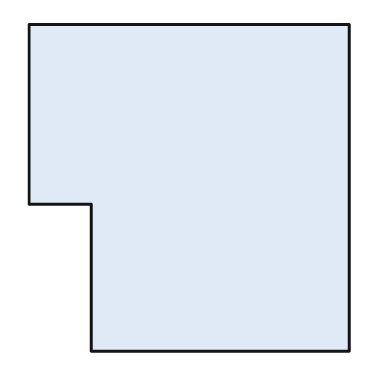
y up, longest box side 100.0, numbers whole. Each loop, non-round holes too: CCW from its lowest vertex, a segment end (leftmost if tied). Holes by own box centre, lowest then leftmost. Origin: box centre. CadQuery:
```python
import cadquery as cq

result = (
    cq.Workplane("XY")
    .moveTo(-30.0, -50.0)
    .lineTo(49.0, -50.0)
    .lineTo(49.0, 50.0)
    .lineTo(-49.0, 50.0)
    .lineTo(-49.0, -5.0)
    .lineTo(-30.0, -5.0)
    .close()
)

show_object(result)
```